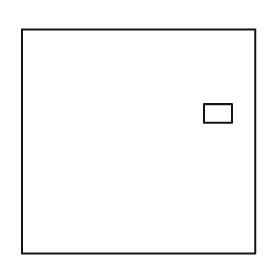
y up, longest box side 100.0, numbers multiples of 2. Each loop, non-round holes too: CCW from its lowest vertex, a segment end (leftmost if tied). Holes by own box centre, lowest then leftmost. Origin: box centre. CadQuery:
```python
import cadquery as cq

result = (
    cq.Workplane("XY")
    .moveTo(-50.0, -48.0)
    .lineTo(50.0, -48.0)
    .lineTo(50.0, 48.0)
    .lineTo(-50.0, 48.0)
    .close()
    .moveTo(28.0, 8.0)
    .lineTo(40.0, 8.0)
    .lineTo(40.0, 16.0)
    .lineTo(28.0, 16.0)
    .close()
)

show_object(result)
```